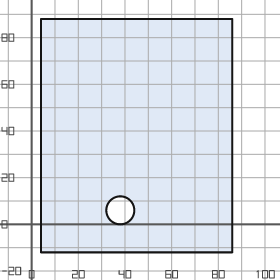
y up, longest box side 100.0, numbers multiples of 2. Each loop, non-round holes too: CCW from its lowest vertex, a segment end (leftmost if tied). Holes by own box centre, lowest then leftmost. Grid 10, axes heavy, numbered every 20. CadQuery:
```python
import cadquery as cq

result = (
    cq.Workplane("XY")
    .moveTo(4.0, -12.0)
    .lineTo(86.0, -12.0)
    .lineTo(86.0, 88.0)
    .lineTo(4.0, 88.0)
    .close()
    .moveTo(38.0, 6.0)
    .circle(6.0)
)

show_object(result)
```